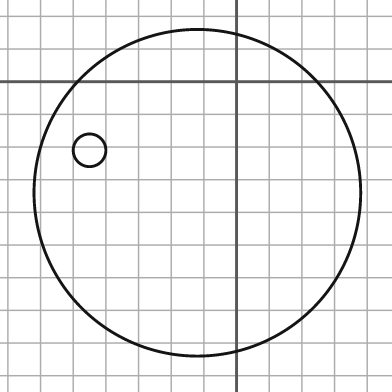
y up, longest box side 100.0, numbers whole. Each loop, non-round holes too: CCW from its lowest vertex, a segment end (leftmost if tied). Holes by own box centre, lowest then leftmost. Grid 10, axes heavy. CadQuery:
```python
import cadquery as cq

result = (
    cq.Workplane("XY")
    .moveTo(-12.0, -34.0)
    .circle(50.0)
    .moveTo(-45.0, -21.0)
    .circle(5.0)
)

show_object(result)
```